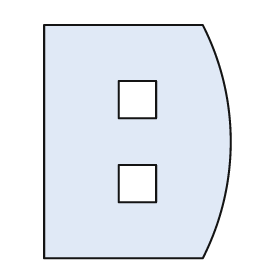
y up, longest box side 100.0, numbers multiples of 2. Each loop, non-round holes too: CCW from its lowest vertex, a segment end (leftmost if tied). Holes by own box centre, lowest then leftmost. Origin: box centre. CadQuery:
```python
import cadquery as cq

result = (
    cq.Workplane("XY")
    .moveTo(-40.0, -50.0)
    .lineTo(28.0, -50.0)
    .threePointArc((40.0, 0.0), (28.0, 50.0))
    .lineTo(-40.0, 50.0)
    .close()
    .moveTo(-8.0, -26.0)
    .lineTo(8.0, -26.0)
    .lineTo(8.0, -10.0)
    .lineTo(-8.0, -10.0)
    .close()
    .moveTo(-8.0, 10.0)
    .lineTo(8.0, 10.0)
    .lineTo(8.0, 26.0)
    .lineTo(-8.0, 26.0)
    .close()
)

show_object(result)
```